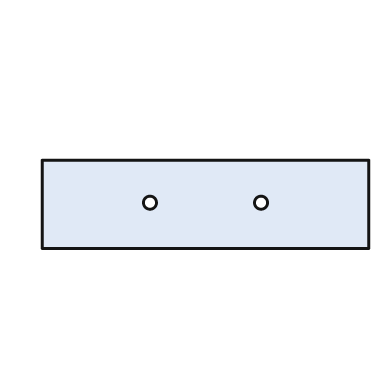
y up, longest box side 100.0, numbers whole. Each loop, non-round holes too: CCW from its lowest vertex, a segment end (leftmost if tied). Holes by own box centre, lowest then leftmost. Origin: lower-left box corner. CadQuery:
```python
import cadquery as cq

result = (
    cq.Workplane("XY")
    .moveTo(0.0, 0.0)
    .lineTo(100.0, 0.0)
    .lineTo(100.0, 27.0)
    .lineTo(0.0, 27.0)
    .close()
    .moveTo(33.0, 14.0)
    .circle(2.0)
    .moveTo(67.0, 14.0)
    .circle(2.0)
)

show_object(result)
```